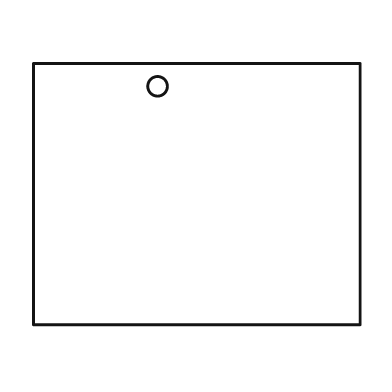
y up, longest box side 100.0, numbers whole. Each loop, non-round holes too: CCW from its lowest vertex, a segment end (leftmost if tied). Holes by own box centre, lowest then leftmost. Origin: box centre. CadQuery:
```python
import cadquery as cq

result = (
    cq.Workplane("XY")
    .moveTo(-50.0, -40.0)
    .lineTo(50.0, -40.0)
    .lineTo(50.0, 40.0)
    .lineTo(-50.0, 40.0)
    .close()
    .moveTo(-12.0, 33.0)
    .circle(3.0)
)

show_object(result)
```